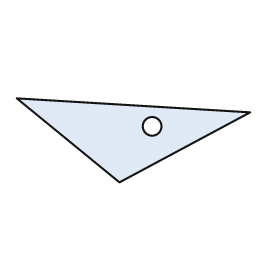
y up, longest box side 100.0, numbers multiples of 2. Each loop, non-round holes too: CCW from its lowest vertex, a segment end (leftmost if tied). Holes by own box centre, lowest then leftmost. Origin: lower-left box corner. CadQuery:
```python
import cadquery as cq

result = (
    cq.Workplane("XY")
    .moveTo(44.0, 0.0)
    .lineTo(100.0, 30.0)
    .lineTo(0.0, 36.0)
    .close()
    .moveTo(58.0, 24.0)
    .circle(4.0)
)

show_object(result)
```